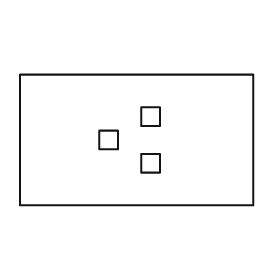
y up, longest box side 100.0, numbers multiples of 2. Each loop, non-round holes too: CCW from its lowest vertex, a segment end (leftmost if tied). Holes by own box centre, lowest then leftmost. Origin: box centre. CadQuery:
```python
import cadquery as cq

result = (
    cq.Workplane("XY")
    .moveTo(-50.0, -28.0)
    .lineTo(50.0, -28.0)
    .lineTo(50.0, 28.0)
    .lineTo(-50.0, 28.0)
    .close()
    .moveTo(2.0, -14.0)
    .lineTo(10.0, -14.0)
    .lineTo(10.0, -6.0)
    .lineTo(2.0, -6.0)
    .close()
    .moveTo(-16.0, -4.0)
    .lineTo(-8.0, -4.0)
    .lineTo(-8.0, 4.0)
    .lineTo(-16.0, 4.0)
    .close()
    .moveTo(2.0, 6.0)
    .lineTo(10.0, 6.0)
    .lineTo(10.0, 14.0)
    .lineTo(2.0, 14.0)
    .close()
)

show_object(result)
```